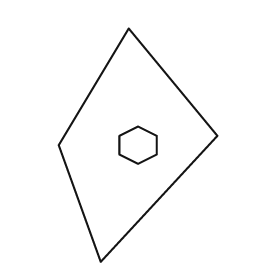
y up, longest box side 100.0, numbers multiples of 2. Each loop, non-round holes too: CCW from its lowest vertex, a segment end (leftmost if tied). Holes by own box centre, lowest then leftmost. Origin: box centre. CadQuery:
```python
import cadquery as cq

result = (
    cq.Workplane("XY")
    .moveTo(-16.0, -50.0)
    .lineTo(34.0, 4.0)
    .lineTo(-4.0, 50.0)
    .lineTo(-34.0, 0.0)
    .close()
    .moveTo(0.0, -8.0)
    .lineTo(8.0, -4.0)
    .lineTo(8.0, 4.0)
    .lineTo(0.0, 8.0)
    .lineTo(-8.0, 4.0)
    .lineTo(-8.0, -4.0)
    .close()
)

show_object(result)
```